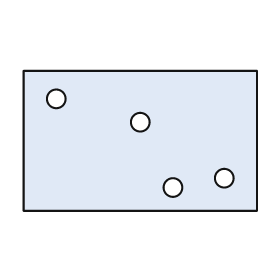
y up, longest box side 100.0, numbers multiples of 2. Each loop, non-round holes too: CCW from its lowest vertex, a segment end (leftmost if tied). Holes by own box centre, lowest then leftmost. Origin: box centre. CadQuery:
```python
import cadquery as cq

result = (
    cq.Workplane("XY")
    .moveTo(-50.0, -30.0)
    .lineTo(50.0, -30.0)
    .lineTo(50.0, 30.0)
    .lineTo(-50.0, 30.0)
    .close()
    .moveTo(14.0, -20.0)
    .circle(4.0)
    .moveTo(36.0, -16.0)
    .circle(4.0)
    .moveTo(0.0, 8.0)
    .circle(4.0)
    .moveTo(-36.0, 18.0)
    .circle(4.0)
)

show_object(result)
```